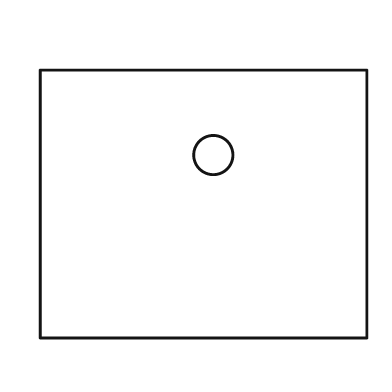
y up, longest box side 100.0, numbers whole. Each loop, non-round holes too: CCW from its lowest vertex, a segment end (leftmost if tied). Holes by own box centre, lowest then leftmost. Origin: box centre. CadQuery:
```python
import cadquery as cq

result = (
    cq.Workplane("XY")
    .moveTo(-50.0, -41.0)
    .lineTo(50.0, -41.0)
    .lineTo(50.0, 41.0)
    .lineTo(-50.0, 41.0)
    .close()
    .moveTo(3.0, 15.0)
    .circle(6.0)
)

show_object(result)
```